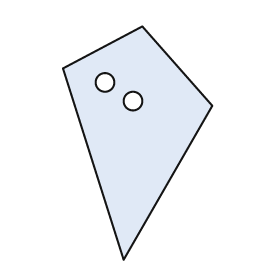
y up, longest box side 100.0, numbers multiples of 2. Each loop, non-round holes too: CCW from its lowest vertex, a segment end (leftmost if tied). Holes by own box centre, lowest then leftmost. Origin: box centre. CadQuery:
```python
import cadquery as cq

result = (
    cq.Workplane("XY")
    .moveTo(-6.0, -50.0)
    .lineTo(32.0, 16.0)
    .lineTo(2.0, 50.0)
    .lineTo(-32.0, 32.0)
    .close()
    .moveTo(-2.0, 18.0)
    .circle(4.0)
    .moveTo(-14.0, 26.0)
    .circle(4.0)
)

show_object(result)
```